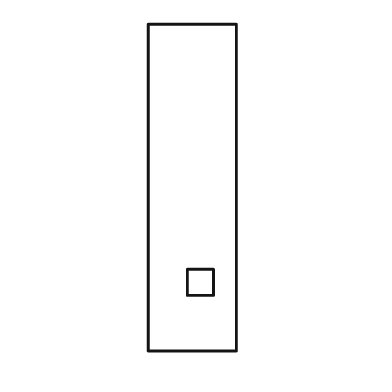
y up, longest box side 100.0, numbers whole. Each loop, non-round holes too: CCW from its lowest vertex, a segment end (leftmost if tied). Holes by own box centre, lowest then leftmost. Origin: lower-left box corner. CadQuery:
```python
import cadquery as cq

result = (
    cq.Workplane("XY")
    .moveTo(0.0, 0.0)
    .lineTo(27.0, 0.0)
    .lineTo(27.0, 100.0)
    .lineTo(0.0, 100.0)
    .close()
    .moveTo(12.0, 17.0)
    .lineTo(20.0, 17.0)
    .lineTo(20.0, 25.0)
    .lineTo(12.0, 25.0)
    .close()
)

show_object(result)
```